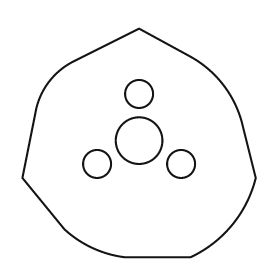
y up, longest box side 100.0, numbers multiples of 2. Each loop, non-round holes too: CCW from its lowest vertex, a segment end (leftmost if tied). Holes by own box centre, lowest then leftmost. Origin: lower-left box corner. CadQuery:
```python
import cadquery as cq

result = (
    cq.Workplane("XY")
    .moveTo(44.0, 0.0)
    .lineTo(72.0, 0.0)
    .threePointArc((90.0, 14.0), (100.0, 34.0))
    .lineTo(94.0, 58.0)
    .threePointArc((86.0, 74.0), (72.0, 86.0))
    .lineTo(50.0, 98.0)
    .lineTo(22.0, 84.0)
    .threePointArc((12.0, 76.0), (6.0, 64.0))
    .lineTo(0.0, 34.0)
    .lineTo(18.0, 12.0)
    .threePointArc((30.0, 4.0), (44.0, 0.0))
    .close()
    .moveTo(32.0, 40.0)
    .circle(6.0)
    .moveTo(68.0, 40.0)
    .circle(6.0)
    .moveTo(50.0, 50.0)
    .circle(10.0)
    .moveTo(50.0, 70.0)
    .circle(6.0)
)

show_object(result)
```